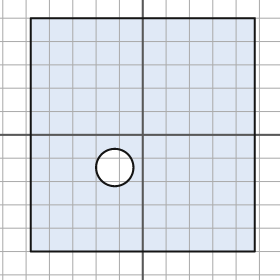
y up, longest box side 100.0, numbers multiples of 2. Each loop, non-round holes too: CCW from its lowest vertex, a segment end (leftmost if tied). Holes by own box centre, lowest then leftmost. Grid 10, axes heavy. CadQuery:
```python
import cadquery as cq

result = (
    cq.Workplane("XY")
    .moveTo(-48.0, -50.0)
    .lineTo(48.0, -50.0)
    .lineTo(48.0, 50.0)
    .lineTo(-48.0, 50.0)
    .close()
    .moveTo(-12.0, -14.0)
    .circle(8.0)
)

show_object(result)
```